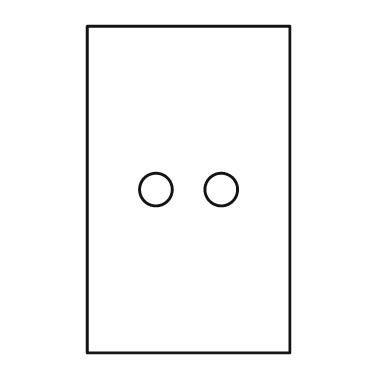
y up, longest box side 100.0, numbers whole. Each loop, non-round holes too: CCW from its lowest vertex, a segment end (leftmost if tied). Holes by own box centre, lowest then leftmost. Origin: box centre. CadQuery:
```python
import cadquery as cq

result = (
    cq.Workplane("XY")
    .moveTo(-31.0, -50.0)
    .lineTo(31.0, -50.0)
    .lineTo(31.0, 50.0)
    .lineTo(-31.0, 50.0)
    .close()
    .moveTo(-10.0, 0.0)
    .circle(5.0)
    .moveTo(10.0, 0.0)
    .circle(5.0)
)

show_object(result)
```